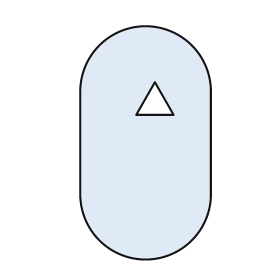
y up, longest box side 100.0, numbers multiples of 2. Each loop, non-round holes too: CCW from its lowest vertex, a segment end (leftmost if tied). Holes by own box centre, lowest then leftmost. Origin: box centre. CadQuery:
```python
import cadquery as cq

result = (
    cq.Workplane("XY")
    .moveTo(-28.0, -22.0)
    .threePointArc((0.0, -50.0), (28.0, -22.0))
    .lineTo(28.0, 22.0)
    .threePointArc((0.0, 50.0), (-28.0, 22.0))
    .close()
    .moveTo(-4.0, 12.0)
    .lineTo(12.0, 12.0)
    .lineTo(4.0, 26.0)
    .close()
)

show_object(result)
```